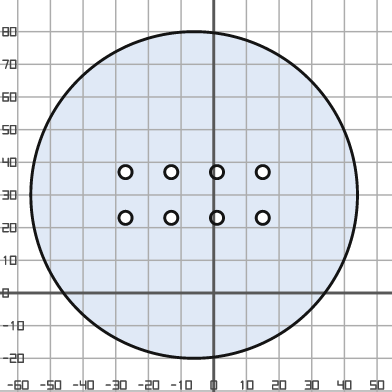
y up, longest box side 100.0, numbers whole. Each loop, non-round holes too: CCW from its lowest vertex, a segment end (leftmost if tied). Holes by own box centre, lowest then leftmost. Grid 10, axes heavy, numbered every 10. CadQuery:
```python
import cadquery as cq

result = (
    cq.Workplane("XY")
    .moveTo(-6.0, 30.0)
    .circle(50.0)
    .moveTo(-27.0, 23.0)
    .circle(2.0)
    .moveTo(-13.0, 23.0)
    .circle(2.0)
    .moveTo(1.0, 23.0)
    .circle(2.0)
    .moveTo(15.0, 23.0)
    .circle(2.0)
    .moveTo(-27.0, 37.0)
    .circle(2.0)
    .moveTo(-13.0, 37.0)
    .circle(2.0)
    .moveTo(1.0, 37.0)
    .circle(2.0)
    .moveTo(15.0, 37.0)
    .circle(2.0)
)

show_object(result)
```